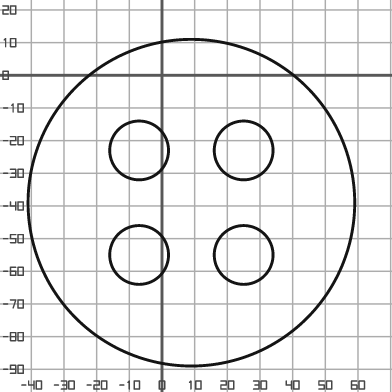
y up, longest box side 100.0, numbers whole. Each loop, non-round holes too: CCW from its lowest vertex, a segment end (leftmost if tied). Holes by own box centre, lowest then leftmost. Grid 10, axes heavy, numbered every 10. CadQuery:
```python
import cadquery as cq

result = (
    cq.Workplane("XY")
    .moveTo(9.0, -39.0)
    .circle(50.0)
    .moveTo(-7.0, -55.0)
    .circle(9.0)
    .moveTo(25.0, -55.0)
    .circle(9.0)
    .moveTo(-7.0, -23.0)
    .circle(9.0)
    .moveTo(25.0, -23.0)
    .circle(9.0)
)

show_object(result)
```